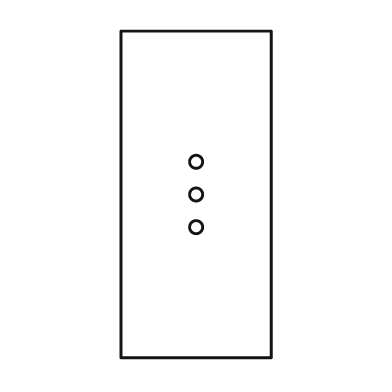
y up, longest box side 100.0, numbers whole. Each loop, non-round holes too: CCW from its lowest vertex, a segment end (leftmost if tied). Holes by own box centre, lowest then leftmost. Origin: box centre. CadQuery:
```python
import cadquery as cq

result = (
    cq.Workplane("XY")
    .moveTo(-23.0, -50.0)
    .lineTo(23.0, -50.0)
    .lineTo(23.0, 50.0)
    .lineTo(-23.0, 50.0)
    .close()
    .moveTo(0.0, -10.0)
    .circle(2.0)
    .moveTo(0.0, 0.0)
    .circle(2.0)
    .moveTo(0.0, 10.0)
    .circle(2.0)
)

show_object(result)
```